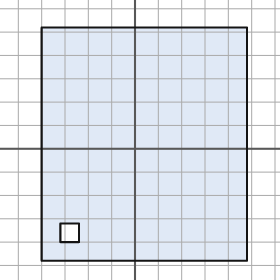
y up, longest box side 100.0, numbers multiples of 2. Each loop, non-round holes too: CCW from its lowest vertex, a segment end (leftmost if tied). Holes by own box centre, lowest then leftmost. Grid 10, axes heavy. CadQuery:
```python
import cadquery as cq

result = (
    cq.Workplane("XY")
    .moveTo(-40.0, -48.0)
    .lineTo(48.0, -48.0)
    .lineTo(48.0, 52.0)
    .lineTo(-40.0, 52.0)
    .close()
    .moveTo(-32.0, -40.0)
    .lineTo(-24.0, -40.0)
    .lineTo(-24.0, -32.0)
    .lineTo(-32.0, -32.0)
    .close()
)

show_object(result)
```